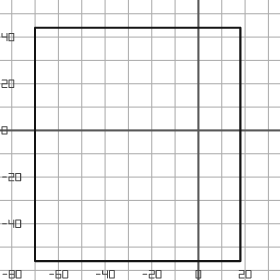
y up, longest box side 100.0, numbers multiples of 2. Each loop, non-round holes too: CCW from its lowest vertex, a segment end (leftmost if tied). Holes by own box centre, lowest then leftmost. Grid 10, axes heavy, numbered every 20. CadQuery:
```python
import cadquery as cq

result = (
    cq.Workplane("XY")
    .moveTo(-70.0, -56.0)
    .lineTo(18.0, -56.0)
    .lineTo(18.0, 44.0)
    .lineTo(-70.0, 44.0)
    .close()
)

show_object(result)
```